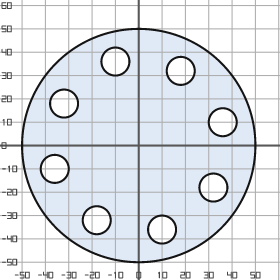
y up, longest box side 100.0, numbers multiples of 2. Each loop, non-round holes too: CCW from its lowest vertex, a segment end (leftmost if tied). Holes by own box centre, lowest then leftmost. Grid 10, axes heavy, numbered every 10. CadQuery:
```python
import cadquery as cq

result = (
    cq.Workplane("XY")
    .moveTo(0.0, 0.0)
    .circle(50.0)
    .moveTo(10.0, -36.0)
    .circle(6.0)
    .moveTo(-18.0, -32.0)
    .circle(6.0)
    .moveTo(32.0, -18.0)
    .circle(6.0)
    .moveTo(-36.0, -10.0)
    .circle(6.0)
    .moveTo(36.0, 10.0)
    .circle(6.0)
    .moveTo(-32.0, 18.0)
    .circle(6.0)
    .moveTo(18.0, 32.0)
    .circle(6.0)
    .moveTo(-10.0, 36.0)
    .circle(6.0)
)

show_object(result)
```